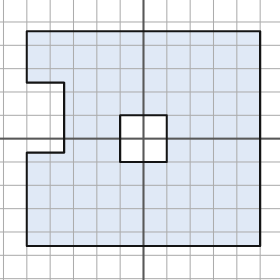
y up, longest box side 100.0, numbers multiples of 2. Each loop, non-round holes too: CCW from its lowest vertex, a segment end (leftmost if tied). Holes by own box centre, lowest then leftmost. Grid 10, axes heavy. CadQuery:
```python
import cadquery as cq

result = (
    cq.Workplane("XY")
    .moveTo(-50.0, -46.0)
    .lineTo(50.0, -46.0)
    .lineTo(50.0, 46.0)
    .lineTo(-50.0, 46.0)
    .lineTo(-50.0, 24.0)
    .lineTo(-34.0, 24.0)
    .lineTo(-34.0, -6.0)
    .lineTo(-50.0, -6.0)
    .close()
    .moveTo(-10.0, -10.0)
    .lineTo(10.0, -10.0)
    .lineTo(10.0, 10.0)
    .lineTo(-10.0, 10.0)
    .close()
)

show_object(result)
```